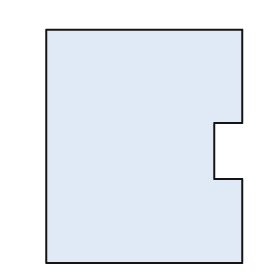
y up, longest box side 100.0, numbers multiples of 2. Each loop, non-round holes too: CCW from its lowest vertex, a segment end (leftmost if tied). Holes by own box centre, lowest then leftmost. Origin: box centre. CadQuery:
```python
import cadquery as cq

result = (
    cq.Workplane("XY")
    .moveTo(-42.0, -50.0)
    .lineTo(42.0, -50.0)
    .lineTo(42.0, -14.0)
    .lineTo(30.0, -14.0)
    .lineTo(30.0, 10.0)
    .lineTo(42.0, 10.0)
    .lineTo(42.0, 50.0)
    .lineTo(-42.0, 50.0)
    .close()
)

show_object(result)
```